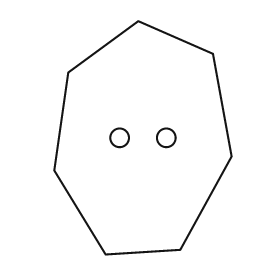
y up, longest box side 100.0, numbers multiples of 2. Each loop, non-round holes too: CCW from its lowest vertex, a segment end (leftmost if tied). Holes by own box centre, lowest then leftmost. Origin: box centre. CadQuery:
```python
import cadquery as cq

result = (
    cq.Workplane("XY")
    .moveTo(-16.0, -50.0)
    .lineTo(16.0, -48.0)
    .lineTo(38.0, -8.0)
    .lineTo(30.0, 36.0)
    .lineTo(-2.0, 50.0)
    .lineTo(-32.0, 28.0)
    .lineTo(-38.0, -14.0)
    .close()
    .moveTo(-10.0, 0.0)
    .circle(4.0)
    .moveTo(10.0, 0.0)
    .circle(4.0)
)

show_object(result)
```